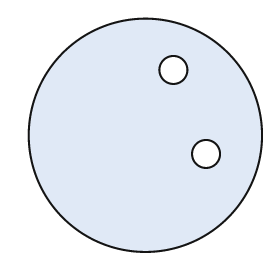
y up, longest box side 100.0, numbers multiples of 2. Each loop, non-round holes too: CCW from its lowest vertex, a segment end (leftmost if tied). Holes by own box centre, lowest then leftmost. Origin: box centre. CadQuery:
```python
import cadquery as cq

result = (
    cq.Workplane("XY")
    .moveTo(0.0, 0.0)
    .circle(50.0)
    .moveTo(26.0, -8.0)
    .circle(6.0)
    .moveTo(12.0, 28.0)
    .circle(6.0)
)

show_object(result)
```